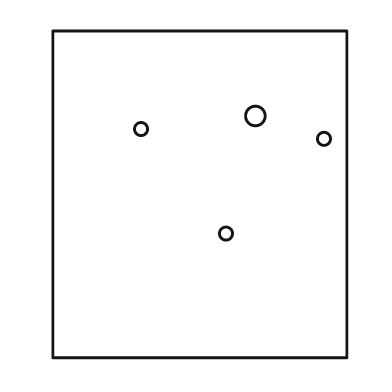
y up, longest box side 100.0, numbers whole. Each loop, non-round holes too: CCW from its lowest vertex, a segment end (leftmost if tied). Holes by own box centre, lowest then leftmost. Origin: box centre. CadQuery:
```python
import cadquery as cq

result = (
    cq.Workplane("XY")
    .moveTo(-45.0, -50.0)
    .lineTo(45.0, -50.0)
    .lineTo(45.0, 50.0)
    .lineTo(-45.0, 50.0)
    .close()
    .moveTo(8.0, -12.0)
    .circle(2.0)
    .moveTo(38.0, 17.0)
    .circle(2.0)
    .moveTo(-18.0, 20.0)
    .circle(2.0)
    .moveTo(17.0, 24.0)
    .circle(3.0)
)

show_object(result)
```